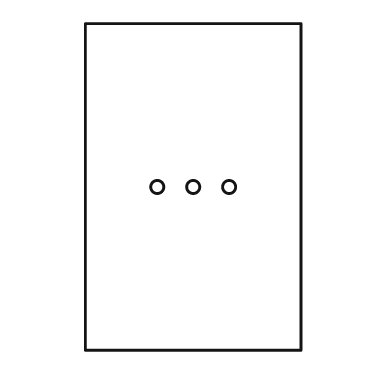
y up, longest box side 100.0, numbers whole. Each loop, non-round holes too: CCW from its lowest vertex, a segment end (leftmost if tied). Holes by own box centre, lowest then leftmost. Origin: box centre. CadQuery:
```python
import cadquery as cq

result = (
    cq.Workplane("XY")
    .moveTo(-33.0, -50.0)
    .lineTo(33.0, -50.0)
    .lineTo(33.0, 50.0)
    .lineTo(-33.0, 50.0)
    .close()
    .moveTo(-11.0, 0.0)
    .circle(2.0)
    .moveTo(0.0, 0.0)
    .circle(2.0)
    .moveTo(11.0, 0.0)
    .circle(2.0)
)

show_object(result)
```